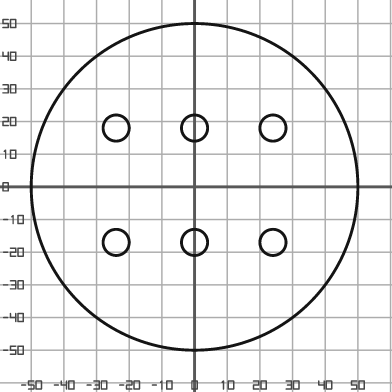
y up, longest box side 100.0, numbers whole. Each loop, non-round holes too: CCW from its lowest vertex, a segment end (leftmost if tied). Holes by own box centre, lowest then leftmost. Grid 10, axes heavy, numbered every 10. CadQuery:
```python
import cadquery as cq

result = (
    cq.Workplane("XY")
    .moveTo(0.0, 0.0)
    .circle(50.0)
    .moveTo(-24.0, -17.0)
    .circle(4.0)
    .moveTo(0.0, -17.0)
    .circle(4.0)
    .moveTo(24.0, -17.0)
    .circle(4.0)
    .moveTo(-24.0, 18.0)
    .circle(4.0)
    .moveTo(0.0, 18.0)
    .circle(4.0)
    .moveTo(24.0, 18.0)
    .circle(4.0)
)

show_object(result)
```